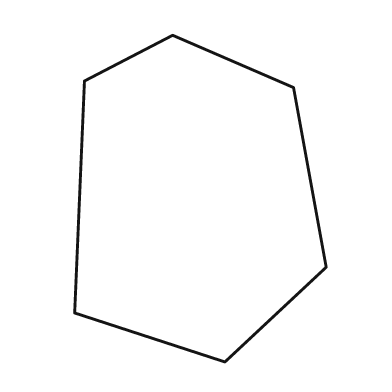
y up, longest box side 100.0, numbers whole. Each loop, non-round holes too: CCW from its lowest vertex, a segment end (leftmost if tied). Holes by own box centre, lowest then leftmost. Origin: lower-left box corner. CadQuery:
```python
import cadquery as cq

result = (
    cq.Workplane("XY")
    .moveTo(46.0, 0.0)
    .lineTo(77.0, 29.0)
    .lineTo(67.0, 84.0)
    .lineTo(30.0, 100.0)
    .lineTo(3.0, 86.0)
    .lineTo(0.0, 15.0)
    .close()
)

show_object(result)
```